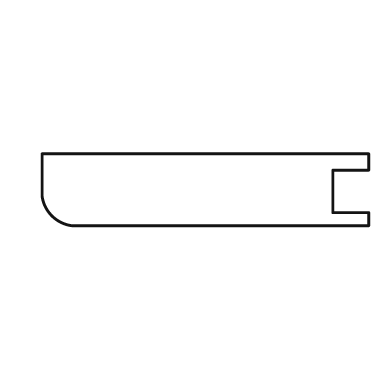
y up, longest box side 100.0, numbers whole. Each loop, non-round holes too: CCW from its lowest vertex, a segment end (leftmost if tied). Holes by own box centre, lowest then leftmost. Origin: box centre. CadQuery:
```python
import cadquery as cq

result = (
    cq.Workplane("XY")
    .moveTo(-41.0, -11.0)
    .lineTo(50.0, -11.0)
    .lineTo(50.0, -7.0)
    .lineTo(39.0, -7.0)
    .lineTo(39.0, 6.0)
    .lineTo(50.0, 6.0)
    .lineTo(50.0, 11.0)
    .lineTo(-50.0, 11.0)
    .lineTo(-50.0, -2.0)
    .threePointArc((-47.0, -8.0), (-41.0, -11.0))
    .close()
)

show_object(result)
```